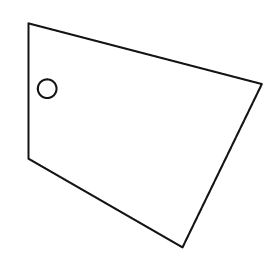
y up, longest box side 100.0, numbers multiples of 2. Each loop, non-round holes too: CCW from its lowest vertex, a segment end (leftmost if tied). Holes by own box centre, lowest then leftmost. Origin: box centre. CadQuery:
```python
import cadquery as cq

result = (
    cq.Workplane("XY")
    .moveTo(16.0, -48.0)
    .lineTo(50.0, 22.0)
    .lineTo(-50.0, 48.0)
    .lineTo(-50.0, -10.0)
    .close()
    .moveTo(-42.0, 20.0)
    .circle(4.0)
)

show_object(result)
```